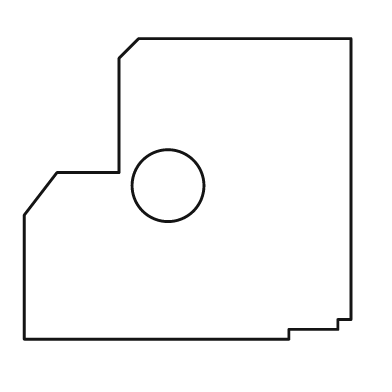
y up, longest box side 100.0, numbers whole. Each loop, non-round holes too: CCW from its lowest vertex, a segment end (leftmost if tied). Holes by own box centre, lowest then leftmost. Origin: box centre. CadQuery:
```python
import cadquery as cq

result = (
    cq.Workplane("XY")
    .moveTo(-50.0, -46.0)
    .lineTo(31.0, -46.0)
    .lineTo(31.0, -43.0)
    .lineTo(46.0, -43.0)
    .lineTo(46.0, -40.0)
    .lineTo(50.0, -40.0)
    .lineTo(50.0, 46.0)
    .lineTo(-15.0, 46.0)
    .lineTo(-21.0, 40.0)
    .lineTo(-21.0, 5.0)
    .lineTo(-40.0, 5.0)
    .lineTo(-50.0, -8.0)
    .close()
    .moveTo(-6.0, 1.0)
    .circle(11.0)
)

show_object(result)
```